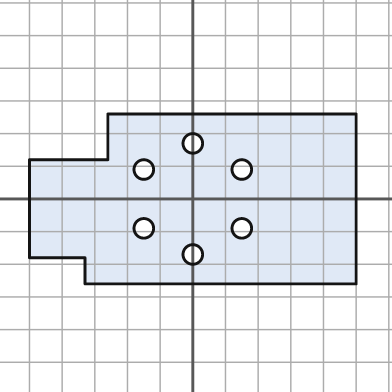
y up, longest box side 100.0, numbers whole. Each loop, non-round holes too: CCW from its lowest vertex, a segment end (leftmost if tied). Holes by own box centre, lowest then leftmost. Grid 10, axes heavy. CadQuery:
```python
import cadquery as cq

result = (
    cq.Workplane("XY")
    .moveTo(-33.0, -26.0)
    .lineTo(50.0, -26.0)
    .lineTo(50.0, 26.0)
    .lineTo(-26.0, 26.0)
    .lineTo(-26.0, 12.0)
    .lineTo(-50.0, 12.0)
    .lineTo(-50.0, -18.0)
    .lineTo(-33.0, -18.0)
    .close()
    .moveTo(0.0, -17.0)
    .circle(3.0)
    .moveTo(-15.0, -9.0)
    .circle(3.0)
    .moveTo(15.0, -9.0)
    .circle(3.0)
    .moveTo(-15.0, 9.0)
    .circle(3.0)
    .moveTo(15.0, 9.0)
    .circle(3.0)
    .moveTo(0.0, 17.0)
    .circle(3.0)
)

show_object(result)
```